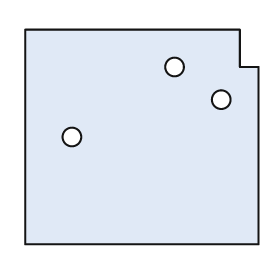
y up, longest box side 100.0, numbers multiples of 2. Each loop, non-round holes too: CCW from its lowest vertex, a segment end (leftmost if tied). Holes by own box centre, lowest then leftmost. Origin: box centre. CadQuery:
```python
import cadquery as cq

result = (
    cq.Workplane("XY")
    .moveTo(-50.0, -46.0)
    .lineTo(50.0, -46.0)
    .lineTo(50.0, 30.0)
    .lineTo(42.0, 30.0)
    .lineTo(42.0, 46.0)
    .lineTo(-50.0, 46.0)
    .close()
    .moveTo(-30.0, 0.0)
    .circle(4.0)
    .moveTo(34.0, 16.0)
    .circle(4.0)
    .moveTo(14.0, 30.0)
    .circle(4.0)
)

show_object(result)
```